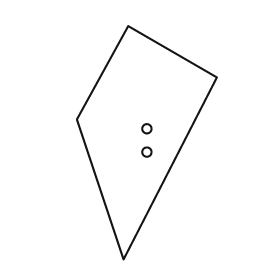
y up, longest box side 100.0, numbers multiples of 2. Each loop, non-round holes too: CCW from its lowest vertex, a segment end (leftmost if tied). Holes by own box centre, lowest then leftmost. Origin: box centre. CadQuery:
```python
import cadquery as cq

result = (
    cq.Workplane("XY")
    .moveTo(-10.0, -50.0)
    .lineTo(30.0, 28.0)
    .lineTo(-8.0, 50.0)
    .lineTo(-30.0, 10.0)
    .close()
    .moveTo(0.0, -4.0)
    .circle(2.0)
    .moveTo(0.0, 6.0)
    .circle(2.0)
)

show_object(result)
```